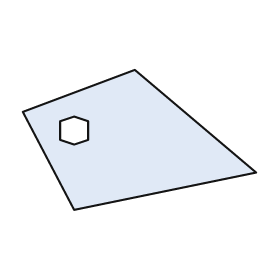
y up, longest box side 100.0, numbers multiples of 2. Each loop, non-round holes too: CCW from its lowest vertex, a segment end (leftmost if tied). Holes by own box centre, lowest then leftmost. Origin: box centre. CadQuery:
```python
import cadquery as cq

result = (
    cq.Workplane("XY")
    .moveTo(-28.0, -30.0)
    .lineTo(50.0, -14.0)
    .lineTo(-2.0, 30.0)
    .lineTo(-50.0, 12.0)
    .close()
    .moveTo(-28.0, -2.0)
    .lineTo(-22.0, 0.0)
    .lineTo(-22.0, 8.0)
    .lineTo(-28.0, 10.0)
    .lineTo(-34.0, 8.0)
    .lineTo(-34.0, 0.0)
    .close()
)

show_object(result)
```